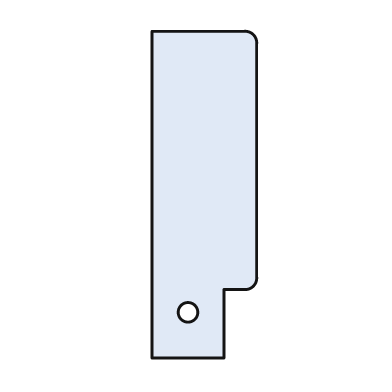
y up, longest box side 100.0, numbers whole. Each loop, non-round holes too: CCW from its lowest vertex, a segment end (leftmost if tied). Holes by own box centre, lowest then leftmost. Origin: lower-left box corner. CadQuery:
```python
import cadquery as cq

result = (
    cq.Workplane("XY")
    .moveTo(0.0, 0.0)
    .lineTo(22.0, 0.0)
    .lineTo(22.0, 21.0)
    .lineTo(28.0, 21.0)
    .threePointArc((31.0, 22.0), (32.0, 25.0))
    .lineTo(32.0, 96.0)
    .threePointArc((31.0, 99.0), (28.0, 100.0))
    .lineTo(0.0, 100.0)
    .close()
    .moveTo(11.0, 14.0)
    .circle(3.0)
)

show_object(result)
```